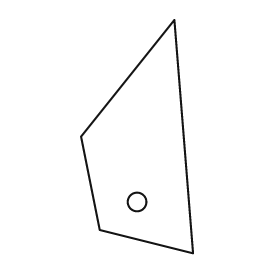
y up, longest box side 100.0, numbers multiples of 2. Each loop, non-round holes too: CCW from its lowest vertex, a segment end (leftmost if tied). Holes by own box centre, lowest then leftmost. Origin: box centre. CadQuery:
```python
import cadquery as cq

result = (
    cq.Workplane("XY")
    .moveTo(24.0, -50.0)
    .lineTo(16.0, 50.0)
    .lineTo(-24.0, 0.0)
    .lineTo(-16.0, -40.0)
    .close()
    .moveTo(0.0, -28.0)
    .circle(4.0)
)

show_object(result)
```